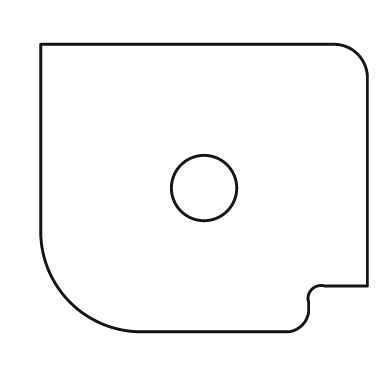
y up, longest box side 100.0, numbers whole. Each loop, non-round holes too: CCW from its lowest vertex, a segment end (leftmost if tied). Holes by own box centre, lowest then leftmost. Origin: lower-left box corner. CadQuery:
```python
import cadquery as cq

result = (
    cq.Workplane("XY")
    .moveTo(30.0, 0.0)
    .lineTo(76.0, 0.0)
    .threePointArc((80.0, 2.0), (82.0, 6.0))
    .lineTo(82.0, 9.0)
    .threePointArc((83.0, 13.0), (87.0, 14.0))
    .lineTo(100.0, 14.0)
    .lineTo(100.0, 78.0)
    .threePointArc((97.0, 85.0), (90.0, 88.0))
    .lineTo(0.0, 88.0)
    .lineTo(0.0, 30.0)
    .threePointArc((9.0, 9.0), (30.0, 0.0))
    .close()
    .moveTo(50.0, 44.0)
    .circle(10.0)
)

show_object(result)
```